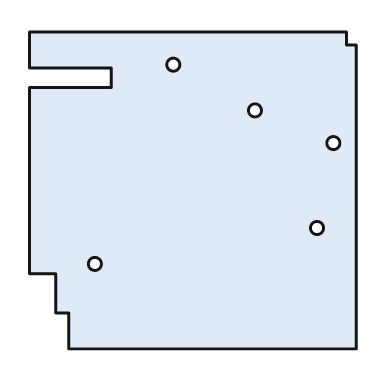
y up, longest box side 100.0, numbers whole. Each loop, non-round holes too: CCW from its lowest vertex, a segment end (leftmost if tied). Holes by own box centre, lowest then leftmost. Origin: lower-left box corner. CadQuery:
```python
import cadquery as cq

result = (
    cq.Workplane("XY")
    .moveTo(12.0, 0.0)
    .lineTo(100.0, 0.0)
    .lineTo(100.0, 93.0)
    .lineTo(97.0, 93.0)
    .lineTo(97.0, 97.0)
    .lineTo(0.0, 97.0)
    .lineTo(0.0, 86.0)
    .lineTo(25.0, 86.0)
    .lineTo(25.0, 80.0)
    .lineTo(0.0, 80.0)
    .lineTo(0.0, 23.0)
    .lineTo(8.0, 23.0)
    .lineTo(8.0, 11.0)
    .lineTo(12.0, 11.0)
    .close()
    .moveTo(20.0, 26.0)
    .circle(2.0)
    .moveTo(88.0, 37.0)
    .circle(2.0)
    .moveTo(93.0, 63.0)
    .circle(2.0)
    .moveTo(69.0, 73.0)
    .circle(2.0)
    .moveTo(44.0, 87.0)
    .circle(2.0)
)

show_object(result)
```